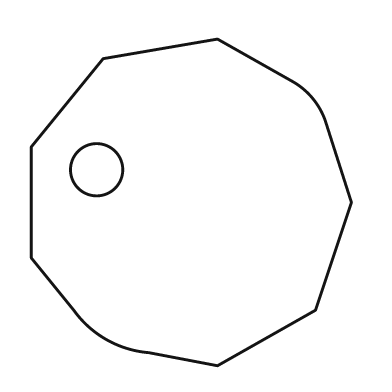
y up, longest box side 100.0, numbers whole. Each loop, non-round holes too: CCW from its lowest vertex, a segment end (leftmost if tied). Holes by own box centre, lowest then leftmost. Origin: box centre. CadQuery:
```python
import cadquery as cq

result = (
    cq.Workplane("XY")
    .moveTo(8.0, -50.0)
    .lineTo(38.0, -33.0)
    .lineTo(49.0, 0.0)
    .lineTo(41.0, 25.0)
    .threePointArc((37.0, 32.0), (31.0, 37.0))
    .lineTo(8.0, 50.0)
    .lineTo(-27.0, 44.0)
    .lineTo(-49.0, 17.0)
    .lineTo(-49.0, -17.0)
    .lineTo(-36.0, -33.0)
    .threePointArc((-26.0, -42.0), (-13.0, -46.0))
    .close()
    .moveTo(-29.0, 10.0)
    .circle(8.0)
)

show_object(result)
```